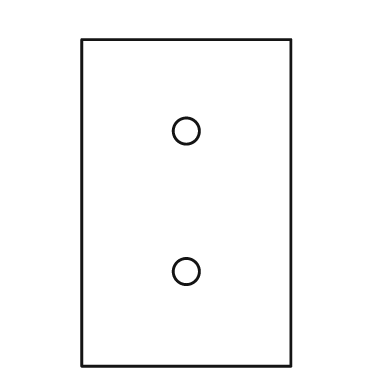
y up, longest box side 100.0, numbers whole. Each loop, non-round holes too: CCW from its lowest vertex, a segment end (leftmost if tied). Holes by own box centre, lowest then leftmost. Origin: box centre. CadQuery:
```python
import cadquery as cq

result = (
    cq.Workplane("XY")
    .moveTo(-32.0, -50.0)
    .lineTo(32.0, -50.0)
    .lineTo(32.0, 50.0)
    .lineTo(-32.0, 50.0)
    .close()
    .moveTo(0.0, -21.0)
    .circle(4.0)
    .moveTo(0.0, 22.0)
    .circle(4.0)
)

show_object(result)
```